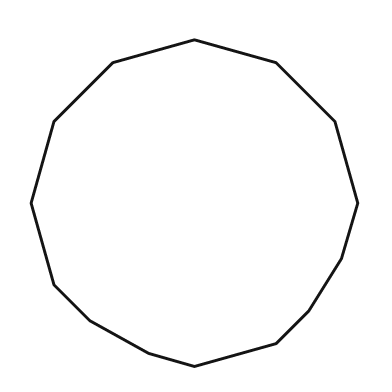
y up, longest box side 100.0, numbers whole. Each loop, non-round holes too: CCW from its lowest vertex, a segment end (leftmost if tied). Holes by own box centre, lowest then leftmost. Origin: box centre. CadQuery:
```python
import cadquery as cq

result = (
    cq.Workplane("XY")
    .moveTo(0.0, -50.0)
    .lineTo(25.0, -43.0)
    .lineTo(35.0, -33.0)
    .lineTo(45.0, -17.0)
    .lineTo(50.0, 0.0)
    .lineTo(43.0, 25.0)
    .lineTo(25.0, 43.0)
    .lineTo(0.0, 50.0)
    .lineTo(-25.0, 43.0)
    .lineTo(-43.0, 25.0)
    .lineTo(-50.0, 0.0)
    .lineTo(-43.0, -25.0)
    .lineTo(-32.0, -36.0)
    .lineTo(-14.0, -46.0)
    .close()
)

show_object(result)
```